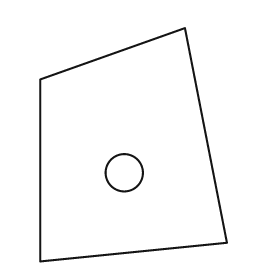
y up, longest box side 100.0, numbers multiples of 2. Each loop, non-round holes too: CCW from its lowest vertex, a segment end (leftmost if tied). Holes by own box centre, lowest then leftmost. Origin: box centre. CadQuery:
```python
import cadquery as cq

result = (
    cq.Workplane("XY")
    .moveTo(-40.0, -50.0)
    .lineTo(40.0, -42.0)
    .lineTo(22.0, 50.0)
    .lineTo(-40.0, 28.0)
    .close()
    .moveTo(-4.0, -12.0)
    .circle(8.0)
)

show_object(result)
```